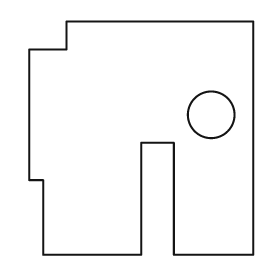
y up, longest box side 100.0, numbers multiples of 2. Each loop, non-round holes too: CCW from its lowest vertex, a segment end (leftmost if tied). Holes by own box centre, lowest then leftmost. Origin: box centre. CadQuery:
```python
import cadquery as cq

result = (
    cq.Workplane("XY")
    .moveTo(-42.0, -50.0)
    .lineTo(0.0, -50.0)
    .lineTo(0.0, -2.0)
    .lineTo(14.0, -2.0)
    .lineTo(14.0, -50.0)
    .lineTo(48.0, -50.0)
    .lineTo(48.0, 50.0)
    .lineTo(-32.0, 50.0)
    .lineTo(-32.0, 38.0)
    .lineTo(-48.0, 38.0)
    .lineTo(-48.0, -18.0)
    .lineTo(-42.0, -18.0)
    .close()
    .moveTo(30.0, 10.0)
    .circle(10.0)
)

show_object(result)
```